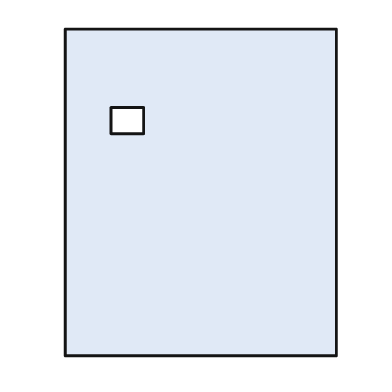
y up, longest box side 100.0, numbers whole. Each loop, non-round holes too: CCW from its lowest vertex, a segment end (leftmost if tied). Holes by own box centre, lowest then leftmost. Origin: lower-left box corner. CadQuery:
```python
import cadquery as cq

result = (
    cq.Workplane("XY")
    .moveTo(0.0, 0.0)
    .lineTo(83.0, 0.0)
    .lineTo(83.0, 100.0)
    .lineTo(0.0, 100.0)
    .close()
    .moveTo(14.0, 68.0)
    .lineTo(24.0, 68.0)
    .lineTo(24.0, 76.0)
    .lineTo(14.0, 76.0)
    .close()
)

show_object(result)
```